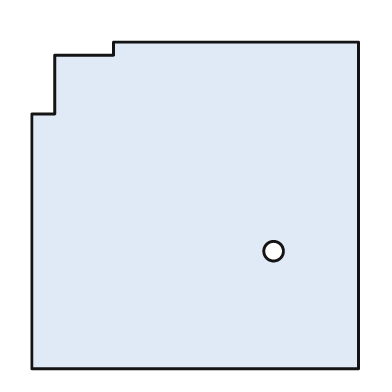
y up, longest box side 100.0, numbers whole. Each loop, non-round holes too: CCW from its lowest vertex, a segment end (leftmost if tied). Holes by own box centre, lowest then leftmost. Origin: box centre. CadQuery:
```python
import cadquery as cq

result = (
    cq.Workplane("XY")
    .moveTo(-50.0, -50.0)
    .lineTo(50.0, -50.0)
    .lineTo(50.0, 50.0)
    .lineTo(-25.0, 50.0)
    .lineTo(-25.0, 46.0)
    .lineTo(-43.0, 46.0)
    .lineTo(-43.0, 28.0)
    .lineTo(-50.0, 28.0)
    .close()
    .moveTo(24.0, -14.0)
    .circle(3.0)
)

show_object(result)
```